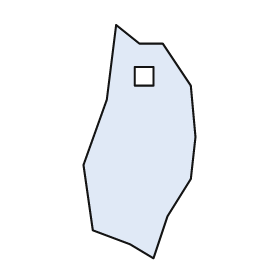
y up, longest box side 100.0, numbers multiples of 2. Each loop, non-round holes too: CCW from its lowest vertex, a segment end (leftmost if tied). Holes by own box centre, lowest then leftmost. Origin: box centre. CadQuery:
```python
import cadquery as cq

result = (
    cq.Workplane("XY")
    .moveTo(6.0, -50.0)
    .lineTo(12.0, -32.0)
    .lineTo(22.0, -16.0)
    .lineTo(24.0, 2.0)
    .lineTo(22.0, 24.0)
    .lineTo(10.0, 42.0)
    .lineTo(0.0, 42.0)
    .lineTo(-10.0, 50.0)
    .lineTo(-14.0, 18.0)
    .lineTo(-24.0, -10.0)
    .lineTo(-20.0, -38.0)
    .lineTo(-4.0, -44.0)
    .close()
    .moveTo(-2.0, 24.0)
    .lineTo(6.0, 24.0)
    .lineTo(6.0, 32.0)
    .lineTo(-2.0, 32.0)
    .close()
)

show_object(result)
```